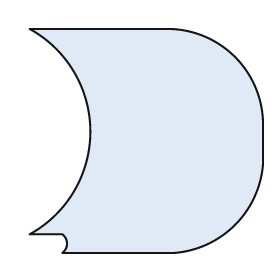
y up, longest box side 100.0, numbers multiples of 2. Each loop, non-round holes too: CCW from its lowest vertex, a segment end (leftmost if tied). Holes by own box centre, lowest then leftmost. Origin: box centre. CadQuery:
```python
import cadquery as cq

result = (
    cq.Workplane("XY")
    .moveTo(-36.0, -48.0)
    .lineTo(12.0, -48.0)
    .threePointArc((38.0, -36.0), (50.0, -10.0))
    .lineTo(50.0, 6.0)
    .threePointArc((38.0, 36.0), (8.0, 48.0))
    .lineTo(-50.0, 48.0)
    .threePointArc((-24.0, 4.0), (-50.0, -40.0))
    .lineTo(-36.0, -40.0)
    .threePointArc((-34.0, -44.0), (-36.0, -48.0))
    .close()
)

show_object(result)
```